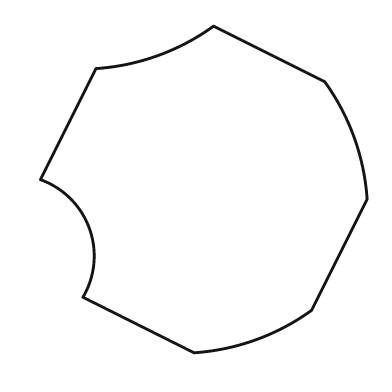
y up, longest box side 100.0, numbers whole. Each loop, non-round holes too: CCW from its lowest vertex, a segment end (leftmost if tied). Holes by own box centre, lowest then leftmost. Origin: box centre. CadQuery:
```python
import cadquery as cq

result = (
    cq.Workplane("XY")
    .moveTo(-3.0, -50.0)
    .threePointArc((16.0, -46.0), (33.0, -37.0))
    .lineTo(50.0, -3.0)
    .threePointArc((46.0, 16.0), (37.0, 33.0))
    .lineTo(3.0, 50.0)
    .threePointArc((-14.0, 41.0), (-33.0, 37.0))
    .lineTo(-50.0, 3.0)
    .threePointArc((-35.0, -12.0), (-37.0, -33.0))
    .close()
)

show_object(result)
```